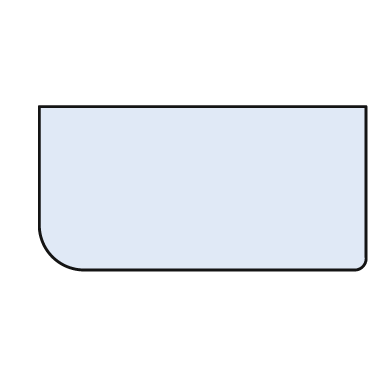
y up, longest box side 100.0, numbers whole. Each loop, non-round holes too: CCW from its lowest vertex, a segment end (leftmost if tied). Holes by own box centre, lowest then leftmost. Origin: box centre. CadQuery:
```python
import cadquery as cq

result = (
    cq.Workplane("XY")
    .moveTo(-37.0, -25.0)
    .lineTo(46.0, -25.0)
    .threePointArc((49.0, -24.0), (50.0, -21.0))
    .lineTo(50.0, 25.0)
    .lineTo(-50.0, 25.0)
    .lineTo(-50.0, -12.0)
    .threePointArc((-46.0, -21.0), (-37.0, -25.0))
    .close()
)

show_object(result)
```